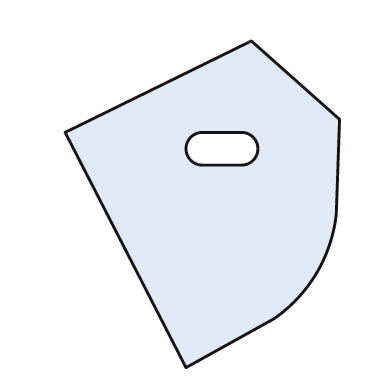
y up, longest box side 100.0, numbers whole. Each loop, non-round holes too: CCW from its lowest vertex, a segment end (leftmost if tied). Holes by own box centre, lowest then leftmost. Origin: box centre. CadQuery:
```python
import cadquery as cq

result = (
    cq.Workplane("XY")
    .moveTo(-5.0, -50.0)
    .lineTo(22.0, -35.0)
    .threePointArc((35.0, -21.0), (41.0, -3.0))
    .lineTo(42.0, 26.0)
    .lineTo(15.0, 50.0)
    .lineTo(-42.0, 22.0)
    .close()
    .moveTo(0.0, 12.0)
    .lineTo(12.0, 12.0)
    .threePointArc((17.0, 17.0), (12.0, 22.0))
    .lineTo(0.0, 22.0)
    .threePointArc((-5.0, 17.0), (0.0, 12.0))
    .close()
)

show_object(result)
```